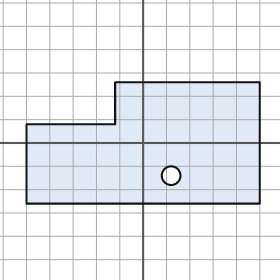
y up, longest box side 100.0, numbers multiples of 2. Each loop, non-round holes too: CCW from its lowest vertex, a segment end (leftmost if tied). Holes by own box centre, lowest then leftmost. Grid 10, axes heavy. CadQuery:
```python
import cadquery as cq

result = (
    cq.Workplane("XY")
    .moveTo(-50.0, -26.0)
    .lineTo(50.0, -26.0)
    .lineTo(50.0, 26.0)
    .lineTo(-12.0, 26.0)
    .lineTo(-12.0, 8.0)
    .lineTo(-50.0, 8.0)
    .close()
    .moveTo(12.0, -14.0)
    .circle(4.0)
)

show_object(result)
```